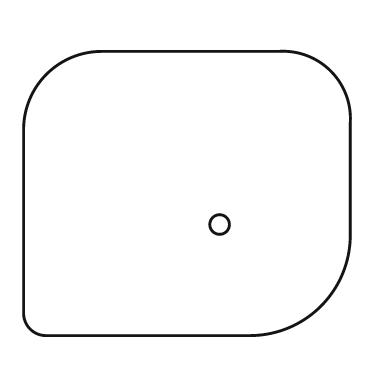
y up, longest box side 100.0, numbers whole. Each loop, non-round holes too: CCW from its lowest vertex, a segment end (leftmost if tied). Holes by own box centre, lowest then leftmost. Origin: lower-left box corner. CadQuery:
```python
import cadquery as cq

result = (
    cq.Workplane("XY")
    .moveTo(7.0, 0.0)
    .lineTo(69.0, 0.0)
    .threePointArc((91.0, 9.0), (100.0, 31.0))
    .lineTo(100.0, 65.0)
    .threePointArc((94.0, 81.0), (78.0, 87.0))
    .lineTo(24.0, 87.0)
    .threePointArc((7.0, 80.0), (0.0, 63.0))
    .lineTo(0.0, 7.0)
    .threePointArc((2.0, 2.0), (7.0, 0.0))
    .close()
    .moveTo(60.0, 34.0)
    .circle(3.0)
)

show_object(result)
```